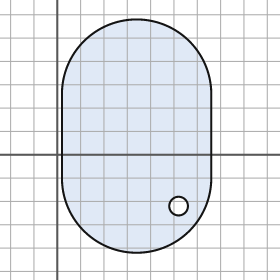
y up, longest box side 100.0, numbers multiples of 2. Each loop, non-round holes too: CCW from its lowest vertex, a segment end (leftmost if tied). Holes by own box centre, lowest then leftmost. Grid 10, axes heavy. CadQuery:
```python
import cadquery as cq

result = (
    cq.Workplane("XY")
    .moveTo(2.0, -10.0)
    .threePointArc((34.0, -42.0), (66.0, -10.0))
    .lineTo(66.0, 26.0)
    .threePointArc((34.0, 58.0), (2.0, 26.0))
    .close()
    .moveTo(52.0, -22.0)
    .circle(4.0)
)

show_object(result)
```